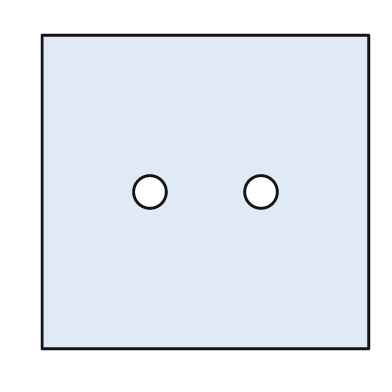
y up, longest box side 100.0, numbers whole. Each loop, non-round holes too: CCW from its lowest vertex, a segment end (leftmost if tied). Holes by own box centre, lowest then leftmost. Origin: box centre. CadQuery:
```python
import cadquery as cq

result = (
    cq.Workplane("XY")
    .moveTo(-50.0, -48.0)
    .lineTo(50.0, -48.0)
    .lineTo(50.0, 48.0)
    .lineTo(-50.0, 48.0)
    .close()
    .moveTo(-17.0, 0.0)
    .circle(5.0)
    .moveTo(17.0, 0.0)
    .circle(5.0)
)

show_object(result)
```